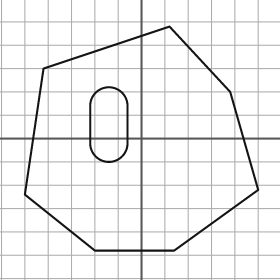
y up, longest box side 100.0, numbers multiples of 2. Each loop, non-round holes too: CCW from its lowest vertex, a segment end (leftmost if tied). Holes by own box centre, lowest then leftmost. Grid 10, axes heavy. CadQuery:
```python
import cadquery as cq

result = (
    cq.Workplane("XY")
    .moveTo(-20.0, -48.0)
    .lineTo(14.0, -48.0)
    .lineTo(50.0, -22.0)
    .lineTo(38.0, 20.0)
    .lineTo(12.0, 48.0)
    .lineTo(-42.0, 30.0)
    .lineTo(-50.0, -24.0)
    .close()
    .moveTo(-22.0, -2.0)
    .threePointArc((-14.0, -10.0), (-6.0, -2.0))
    .lineTo(-6.0, 14.0)
    .threePointArc((-14.0, 22.0), (-22.0, 14.0))
    .close()
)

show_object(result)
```